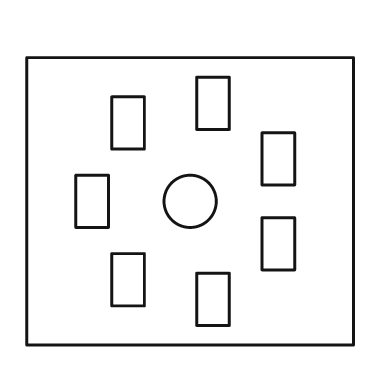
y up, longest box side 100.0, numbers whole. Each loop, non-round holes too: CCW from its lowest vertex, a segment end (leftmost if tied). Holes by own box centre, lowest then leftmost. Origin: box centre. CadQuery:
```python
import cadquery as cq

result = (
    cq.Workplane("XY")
    .moveTo(-50.0, -44.0)
    .lineTo(50.0, -44.0)
    .lineTo(50.0, 44.0)
    .lineTo(-50.0, 44.0)
    .close()
    .moveTo(2.0, -38.0)
    .lineTo(12.0, -38.0)
    .lineTo(12.0, -22.0)
    .lineTo(2.0, -22.0)
    .close()
    .moveTo(-24.0, -32.0)
    .lineTo(-14.0, -32.0)
    .lineTo(-14.0, -16.0)
    .lineTo(-24.0, -16.0)
    .close()
    .moveTo(22.0, -21.0)
    .lineTo(32.0, -21.0)
    .lineTo(32.0, -5.0)
    .lineTo(22.0, -5.0)
    .close()
    .moveTo(-35.0, -8.0)
    .lineTo(-25.0, -8.0)
    .lineTo(-25.0, 8.0)
    .lineTo(-35.0, 8.0)
    .close()
    .moveTo(0.0, 0.0)
    .circle(8.0)
    .moveTo(22.0, 5.0)
    .lineTo(32.0, 5.0)
    .lineTo(32.0, 21.0)
    .lineTo(22.0, 21.0)
    .close()
    .moveTo(-24.0, 16.0)
    .lineTo(-14.0, 16.0)
    .lineTo(-14.0, 32.0)
    .lineTo(-24.0, 32.0)
    .close()
    .moveTo(2.0, 22.0)
    .lineTo(12.0, 22.0)
    .lineTo(12.0, 38.0)
    .lineTo(2.0, 38.0)
    .close()
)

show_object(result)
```